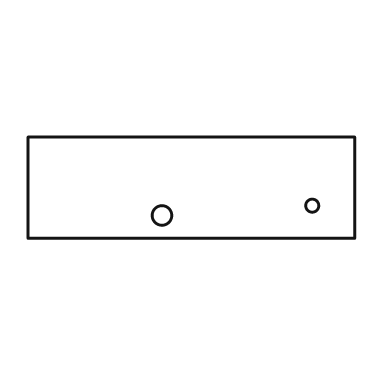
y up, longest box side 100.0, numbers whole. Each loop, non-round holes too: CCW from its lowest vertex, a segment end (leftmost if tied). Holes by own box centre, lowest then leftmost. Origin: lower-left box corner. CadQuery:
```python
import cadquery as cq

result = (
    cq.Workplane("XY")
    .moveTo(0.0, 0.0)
    .lineTo(100.0, 0.0)
    .lineTo(100.0, 31.0)
    .lineTo(0.0, 31.0)
    .close()
    .moveTo(41.0, 7.0)
    .circle(3.0)
    .moveTo(87.0, 10.0)
    .circle(2.0)
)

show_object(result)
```